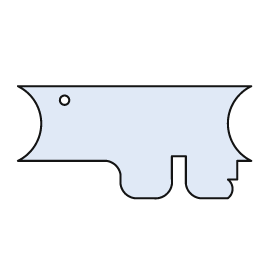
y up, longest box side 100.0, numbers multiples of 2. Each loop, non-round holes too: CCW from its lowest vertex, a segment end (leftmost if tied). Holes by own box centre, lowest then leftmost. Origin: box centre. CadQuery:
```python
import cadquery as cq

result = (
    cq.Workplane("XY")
    .moveTo(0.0, -24.0)
    .lineTo(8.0, -24.0)
    .threePointArc((14.0, -22.0), (16.0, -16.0))
    .lineTo(16.0, -6.0)
    .lineTo(22.0, -6.0)
    .lineTo(22.0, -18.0)
    .threePointArc((24.0, -22.0), (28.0, -24.0))
    .lineTo(40.0, -24.0)
    .threePointArc((42.0, -20.0), (40.0, -16.0))
    .lineTo(44.0, -16.0)
    .lineTo(44.0, -8.0)
    .lineTo(50.0, -8.0)
    .threePointArc((40.0, 8.0), (50.0, 24.0))
    .lineTo(-50.0, 24.0)
    .threePointArc((-40.0, 8.0), (-50.0, -8.0))
    .lineTo(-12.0, -8.0)
    .threePointArc((-8.0, -10.0), (-6.0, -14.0))
    .lineTo(-6.0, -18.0)
    .threePointArc((-4.0, -22.0), (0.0, -24.0))
    .close()
    .moveTo(-30.0, 18.0)
    .circle(2.0)
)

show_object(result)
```